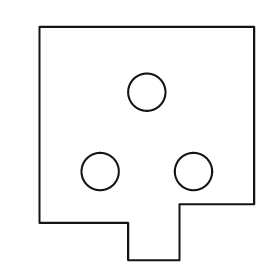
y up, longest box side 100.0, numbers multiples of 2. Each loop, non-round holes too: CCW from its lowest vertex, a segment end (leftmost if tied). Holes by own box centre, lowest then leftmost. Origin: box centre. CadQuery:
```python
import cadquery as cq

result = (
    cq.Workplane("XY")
    .moveTo(-8.0, -50.0)
    .lineTo(14.0, -50.0)
    .lineTo(14.0, -26.0)
    .lineTo(46.0, -26.0)
    .lineTo(46.0, 50.0)
    .lineTo(-46.0, 50.0)
    .lineTo(-46.0, -34.0)
    .lineTo(-8.0, -34.0)
    .close()
    .moveTo(-20.0, -12.0)
    .circle(8.0)
    .moveTo(20.0, -12.0)
    .circle(8.0)
    .moveTo(0.0, 22.0)
    .circle(8.0)
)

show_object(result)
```